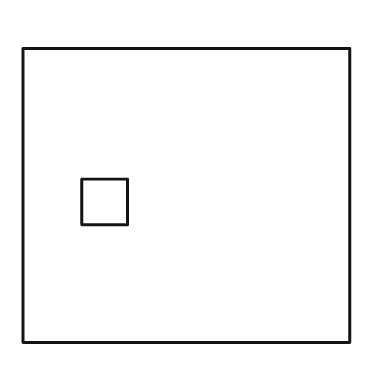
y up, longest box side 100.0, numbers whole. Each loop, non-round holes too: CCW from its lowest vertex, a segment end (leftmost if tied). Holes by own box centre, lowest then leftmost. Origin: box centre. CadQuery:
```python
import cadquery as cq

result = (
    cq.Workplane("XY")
    .moveTo(-50.0, -45.0)
    .lineTo(50.0, -45.0)
    .lineTo(50.0, 45.0)
    .lineTo(-50.0, 45.0)
    .close()
    .moveTo(-32.0, -9.0)
    .lineTo(-18.0, -9.0)
    .lineTo(-18.0, 5.0)
    .lineTo(-32.0, 5.0)
    .close()
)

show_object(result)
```